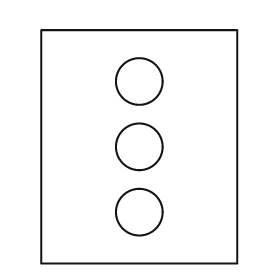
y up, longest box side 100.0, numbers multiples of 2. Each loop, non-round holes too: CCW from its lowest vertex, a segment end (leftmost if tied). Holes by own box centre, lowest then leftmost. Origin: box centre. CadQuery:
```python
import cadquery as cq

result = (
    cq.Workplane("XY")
    .moveTo(-42.0, -50.0)
    .lineTo(42.0, -50.0)
    .lineTo(42.0, 50.0)
    .lineTo(-42.0, 50.0)
    .close()
    .moveTo(0.0, -28.0)
    .circle(10.0)
    .moveTo(0.0, 0.0)
    .circle(10.0)
    .moveTo(0.0, 28.0)
    .circle(10.0)
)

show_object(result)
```